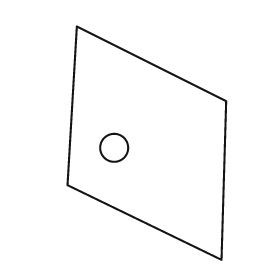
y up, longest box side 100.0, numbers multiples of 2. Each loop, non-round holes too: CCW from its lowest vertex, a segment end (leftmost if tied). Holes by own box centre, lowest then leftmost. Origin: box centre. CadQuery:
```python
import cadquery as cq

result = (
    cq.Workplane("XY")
    .moveTo(32.0, -50.0)
    .lineTo(34.0, 18.0)
    .lineTo(-30.0, 50.0)
    .lineTo(-34.0, -18.0)
    .close()
    .moveTo(-14.0, -2.0)
    .circle(6.0)
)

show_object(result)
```